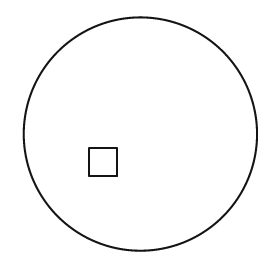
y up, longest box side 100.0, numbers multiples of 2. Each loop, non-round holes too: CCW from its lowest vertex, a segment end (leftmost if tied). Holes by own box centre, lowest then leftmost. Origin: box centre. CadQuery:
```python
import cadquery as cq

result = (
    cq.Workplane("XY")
    .moveTo(0.0, 0.0)
    .circle(50.0)
    .moveTo(-22.0, -18.0)
    .lineTo(-10.0, -18.0)
    .lineTo(-10.0, -6.0)
    .lineTo(-22.0, -6.0)
    .close()
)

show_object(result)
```